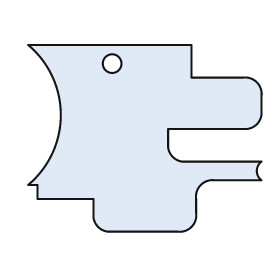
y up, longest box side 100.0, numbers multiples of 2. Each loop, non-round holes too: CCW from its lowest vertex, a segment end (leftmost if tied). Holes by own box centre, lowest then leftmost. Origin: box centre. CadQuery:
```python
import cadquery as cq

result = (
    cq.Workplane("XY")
    .moveTo(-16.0, -40.0)
    .lineTo(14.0, -40.0)
    .threePointArc((20.0, -38.0), (22.0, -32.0))
    .lineTo(22.0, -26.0)
    .threePointArc((24.0, -20.0), (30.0, -18.0))
    .lineTo(50.0, -18.0)
    .threePointArc((48.0, -14.0), (50.0, -10.0))
    .lineTo(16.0, -10.0)
    .threePointArc((12.0, -8.0), (10.0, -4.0))
    .lineTo(10.0, 4.0)
    .lineTo(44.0, 4.0)
    .threePointArc((48.0, 6.0), (50.0, 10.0))
    .lineTo(50.0, 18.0)
    .threePointArc((48.0, 24.0), (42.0, 26.0))
    .lineTo(20.0, 26.0)
    .lineTo(20.0, 40.0)
    .lineTo(-50.0, 40.0)
    .threePointArc((-36.0, 10.0), (-50.0, -20.0))
    .lineTo(-46.0, -20.0)
    .lineTo(-46.0, -26.0)
    .lineTo(-22.0, -26.0)
    .lineTo(-22.0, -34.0)
    .threePointArc((-20.0, -38.0), (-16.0, -40.0))
    .close()
    .moveTo(-14.0, 32.0)
    .circle(4.0)
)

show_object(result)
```